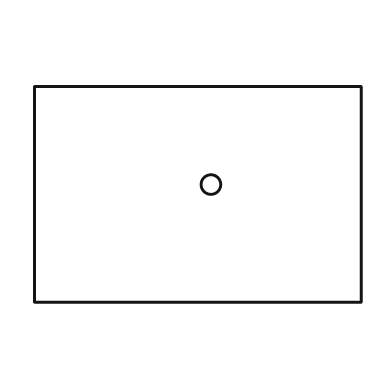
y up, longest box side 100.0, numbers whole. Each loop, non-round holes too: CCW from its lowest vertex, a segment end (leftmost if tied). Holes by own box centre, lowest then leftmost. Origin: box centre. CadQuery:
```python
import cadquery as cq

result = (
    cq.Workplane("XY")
    .moveTo(-50.0, -33.0)
    .lineTo(50.0, -33.0)
    .lineTo(50.0, 33.0)
    .lineTo(-50.0, 33.0)
    .close()
    .moveTo(4.0, 3.0)
    .circle(3.0)
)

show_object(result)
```